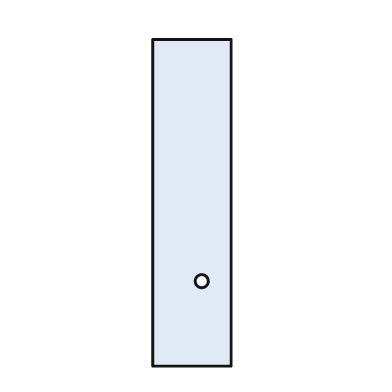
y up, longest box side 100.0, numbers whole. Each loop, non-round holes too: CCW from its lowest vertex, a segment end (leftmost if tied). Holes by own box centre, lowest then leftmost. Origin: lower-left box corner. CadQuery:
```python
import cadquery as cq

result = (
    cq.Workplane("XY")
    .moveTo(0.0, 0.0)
    .lineTo(24.0, 0.0)
    .lineTo(24.0, 100.0)
    .lineTo(0.0, 100.0)
    .close()
    .moveTo(15.0, 26.0)
    .circle(2.0)
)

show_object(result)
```